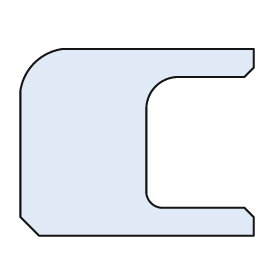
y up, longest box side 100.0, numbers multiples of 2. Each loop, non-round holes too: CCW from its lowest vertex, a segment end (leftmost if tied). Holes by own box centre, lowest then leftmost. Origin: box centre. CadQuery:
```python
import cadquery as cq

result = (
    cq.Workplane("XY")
    .moveTo(-42.0, -40.0)
    .lineTo(50.0, -40.0)
    .lineTo(50.0, -32.0)
    .lineTo(46.0, -28.0)
    .lineTo(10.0, -28.0)
    .threePointArc((6.0, -26.0), (4.0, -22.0))
    .lineTo(4.0, 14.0)
    .threePointArc((8.0, 24.0), (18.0, 28.0))
    .lineTo(46.0, 28.0)
    .lineTo(50.0, 32.0)
    .lineTo(50.0, 40.0)
    .lineTo(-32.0, 40.0)
    .threePointArc((-44.0, 34.0), (-50.0, 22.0))
    .lineTo(-50.0, -32.0)
    .close()
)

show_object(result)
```